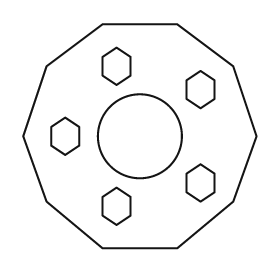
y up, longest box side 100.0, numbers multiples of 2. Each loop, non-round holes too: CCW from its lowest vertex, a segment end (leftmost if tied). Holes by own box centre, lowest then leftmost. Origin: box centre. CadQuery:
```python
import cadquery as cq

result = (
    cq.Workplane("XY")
    .moveTo(-16.0, -48.0)
    .lineTo(16.0, -48.0)
    .lineTo(40.0, -28.0)
    .lineTo(50.0, 0.0)
    .lineTo(40.0, 30.0)
    .lineTo(16.0, 48.0)
    .lineTo(-16.0, 48.0)
    .lineTo(-40.0, 30.0)
    .lineTo(-50.0, 0.0)
    .lineTo(-40.0, -28.0)
    .close()
    .moveTo(-10.0, -38.0)
    .lineTo(-4.0, -34.0)
    .lineTo(-4.0, -26.0)
    .lineTo(-10.0, -22.0)
    .lineTo(-16.0, -26.0)
    .lineTo(-16.0, -34.0)
    .close()
    .moveTo(26.0, -28.0)
    .lineTo(32.0, -24.0)
    .lineTo(32.0, -16.0)
    .lineTo(26.0, -12.0)
    .lineTo(20.0, -16.0)
    .lineTo(20.0, -24.0)
    .close()
    .moveTo(-32.0, -8.0)
    .lineTo(-26.0, -4.0)
    .lineTo(-26.0, 4.0)
    .lineTo(-32.0, 8.0)
    .lineTo(-38.0, 4.0)
    .lineTo(-38.0, -4.0)
    .close()
    .moveTo(0.0, 0.0)
    .circle(18.0)
    .moveTo(26.0, 12.0)
    .lineTo(32.0, 16.0)
    .lineTo(32.0, 24.0)
    .lineTo(26.0, 28.0)
    .lineTo(20.0, 24.0)
    .lineTo(20.0, 16.0)
    .close()
    .moveTo(-10.0, 22.0)
    .lineTo(-4.0, 26.0)
    .lineTo(-4.0, 34.0)
    .lineTo(-10.0, 38.0)
    .lineTo(-16.0, 34.0)
    .lineTo(-16.0, 26.0)
    .close()
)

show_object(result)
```